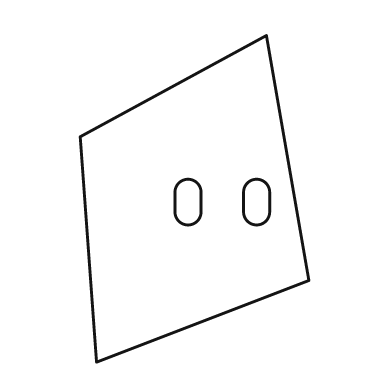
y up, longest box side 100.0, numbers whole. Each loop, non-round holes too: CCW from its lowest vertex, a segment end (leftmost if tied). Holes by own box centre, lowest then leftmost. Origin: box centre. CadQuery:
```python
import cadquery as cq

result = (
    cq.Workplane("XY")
    .moveTo(-30.0, -50.0)
    .lineTo(35.0, -25.0)
    .lineTo(22.0, 50.0)
    .lineTo(-35.0, 19.0)
    .close()
    .moveTo(-6.0, -4.0)
    .threePointArc((-2.0, -8.0), (2.0, -4.0))
    .lineTo(2.0, 2.0)
    .threePointArc((-2.0, 6.0), (-6.0, 2.0))
    .close()
    .moveTo(15.0, -4.0)
    .threePointArc((19.0, -8.0), (23.0, -4.0))
    .lineTo(23.0, 2.0)
    .threePointArc((19.0, 6.0), (15.0, 2.0))
    .close()
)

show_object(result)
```